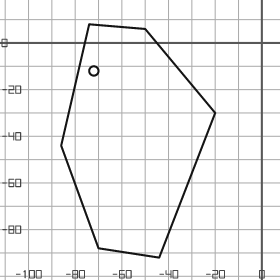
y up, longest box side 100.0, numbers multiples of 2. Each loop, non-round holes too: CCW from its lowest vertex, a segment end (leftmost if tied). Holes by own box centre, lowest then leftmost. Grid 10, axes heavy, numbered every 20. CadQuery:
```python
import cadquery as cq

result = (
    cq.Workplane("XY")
    .moveTo(-44.0, -92.0)
    .lineTo(-20.0, -30.0)
    .lineTo(-50.0, 6.0)
    .lineTo(-74.0, 8.0)
    .lineTo(-86.0, -44.0)
    .lineTo(-70.0, -88.0)
    .close()
    .moveTo(-72.0, -12.0)
    .circle(2.0)
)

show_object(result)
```